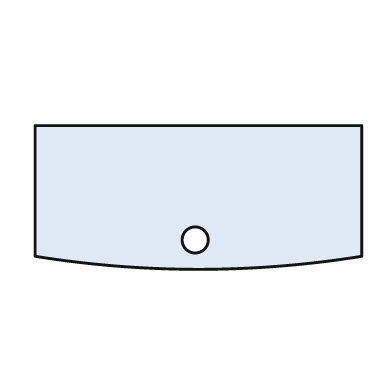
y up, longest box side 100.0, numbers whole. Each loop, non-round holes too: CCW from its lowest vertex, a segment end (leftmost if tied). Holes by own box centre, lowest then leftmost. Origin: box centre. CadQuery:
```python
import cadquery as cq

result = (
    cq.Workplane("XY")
    .moveTo(-50.0, -18.0)
    .threePointArc((0.0, -22.0), (50.0, -18.0))
    .lineTo(50.0, 22.0)
    .lineTo(-50.0, 22.0)
    .close()
    .moveTo(-1.0, -13.0)
    .circle(4.0)
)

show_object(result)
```